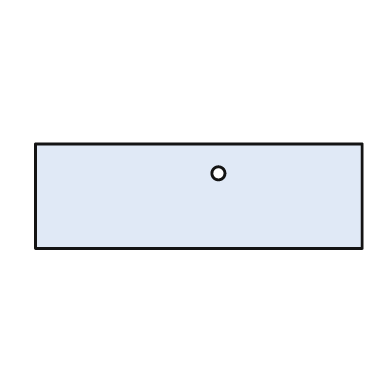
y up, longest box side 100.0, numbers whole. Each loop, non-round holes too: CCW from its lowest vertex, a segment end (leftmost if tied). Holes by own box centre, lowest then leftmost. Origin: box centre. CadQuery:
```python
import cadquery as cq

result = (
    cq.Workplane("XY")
    .moveTo(-50.0, -16.0)
    .lineTo(50.0, -16.0)
    .lineTo(50.0, 16.0)
    .lineTo(-50.0, 16.0)
    .close()
    .moveTo(6.0, 7.0)
    .circle(2.0)
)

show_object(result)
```